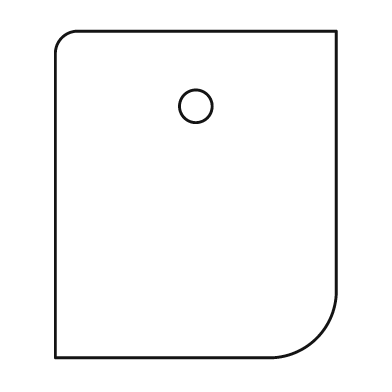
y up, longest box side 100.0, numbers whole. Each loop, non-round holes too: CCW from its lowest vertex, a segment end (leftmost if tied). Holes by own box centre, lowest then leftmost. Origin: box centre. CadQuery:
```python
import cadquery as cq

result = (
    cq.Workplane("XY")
    .moveTo(-43.0, -50.0)
    .lineTo(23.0, -50.0)
    .threePointArc((37.0, -44.0), (43.0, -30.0))
    .lineTo(43.0, 50.0)
    .lineTo(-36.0, 50.0)
    .threePointArc((-41.0, 48.0), (-43.0, 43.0))
    .close()
    .moveTo(0.0, 27.0)
    .circle(5.0)
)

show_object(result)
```